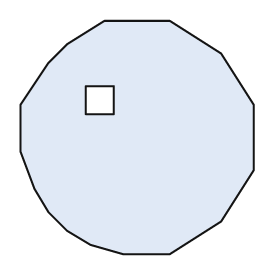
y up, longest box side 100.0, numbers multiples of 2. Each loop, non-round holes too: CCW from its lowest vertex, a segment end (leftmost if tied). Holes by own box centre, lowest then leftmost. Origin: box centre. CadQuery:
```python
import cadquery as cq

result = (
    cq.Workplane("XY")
    .moveTo(-6.0, -50.0)
    .lineTo(14.0, -50.0)
    .lineTo(36.0, -36.0)
    .lineTo(50.0, -14.0)
    .lineTo(50.0, 14.0)
    .lineTo(36.0, 36.0)
    .lineTo(14.0, 50.0)
    .lineTo(-14.0, 50.0)
    .lineTo(-30.0, 40.0)
    .lineTo(-38.0, 32.0)
    .lineTo(-50.0, 14.0)
    .lineTo(-50.0, -6.0)
    .lineTo(-44.0, -22.0)
    .lineTo(-38.0, -32.0)
    .lineTo(-30.0, -40.0)
    .lineTo(-20.0, -46.0)
    .close()
    .moveTo(-22.0, 10.0)
    .lineTo(-10.0, 10.0)
    .lineTo(-10.0, 22.0)
    .lineTo(-22.0, 22.0)
    .close()
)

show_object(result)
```